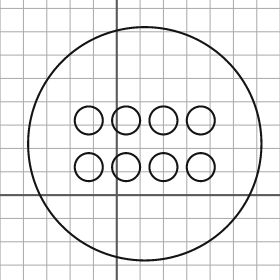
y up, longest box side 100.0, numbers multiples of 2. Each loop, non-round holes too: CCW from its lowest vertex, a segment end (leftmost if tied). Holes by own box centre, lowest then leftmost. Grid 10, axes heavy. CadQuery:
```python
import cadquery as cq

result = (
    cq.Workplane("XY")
    .moveTo(12.0, 22.0)
    .circle(50.0)
    .moveTo(-12.0, 12.0)
    .circle(6.0)
    .moveTo(4.0, 12.0)
    .circle(6.0)
    .moveTo(20.0, 12.0)
    .circle(6.0)
    .moveTo(36.0, 12.0)
    .circle(6.0)
    .moveTo(-12.0, 32.0)
    .circle(6.0)
    .moveTo(4.0, 32.0)
    .circle(6.0)
    .moveTo(20.0, 32.0)
    .circle(6.0)
    .moveTo(36.0, 32.0)
    .circle(6.0)
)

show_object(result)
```